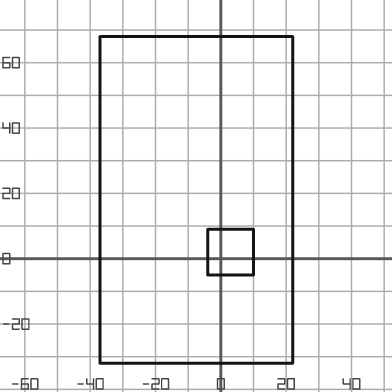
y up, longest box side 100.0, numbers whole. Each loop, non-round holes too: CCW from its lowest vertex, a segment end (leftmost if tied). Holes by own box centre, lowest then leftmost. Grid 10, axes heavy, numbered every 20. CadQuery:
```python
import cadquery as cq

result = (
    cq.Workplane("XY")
    .moveTo(-37.0, -32.0)
    .lineTo(22.0, -32.0)
    .lineTo(22.0, 68.0)
    .lineTo(-37.0, 68.0)
    .close()
    .moveTo(-4.0, -5.0)
    .lineTo(10.0, -5.0)
    .lineTo(10.0, 9.0)
    .lineTo(-4.0, 9.0)
    .close()
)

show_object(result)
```